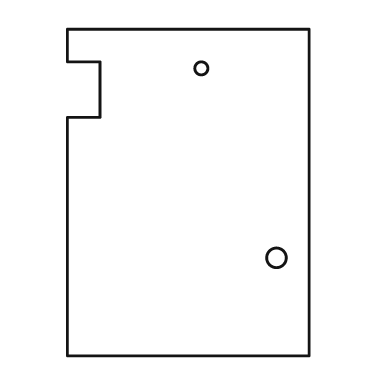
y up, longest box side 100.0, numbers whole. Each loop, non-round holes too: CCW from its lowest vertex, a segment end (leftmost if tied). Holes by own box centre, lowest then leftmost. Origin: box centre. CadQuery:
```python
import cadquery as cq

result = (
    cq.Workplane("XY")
    .moveTo(-37.0, -50.0)
    .lineTo(37.0, -50.0)
    .lineTo(37.0, 50.0)
    .lineTo(-37.0, 50.0)
    .lineTo(-37.0, 40.0)
    .lineTo(-27.0, 40.0)
    .lineTo(-27.0, 23.0)
    .lineTo(-37.0, 23.0)
    .close()
    .moveTo(27.0, -20.0)
    .circle(3.0)
    .moveTo(4.0, 38.0)
    .circle(2.0)
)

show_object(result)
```